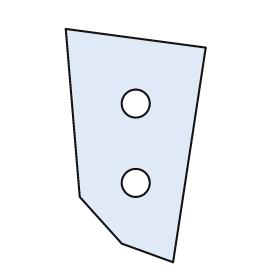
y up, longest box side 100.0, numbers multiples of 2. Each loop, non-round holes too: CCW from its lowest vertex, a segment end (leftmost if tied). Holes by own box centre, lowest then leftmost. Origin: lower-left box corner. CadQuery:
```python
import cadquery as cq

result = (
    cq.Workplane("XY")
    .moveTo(46.0, 0.0)
    .lineTo(60.0, 92.0)
    .lineTo(0.0, 100.0)
    .lineTo(6.0, 28.0)
    .lineTo(24.0, 8.0)
    .close()
    .moveTo(30.0, 34.0)
    .circle(6.0)
    .moveTo(30.0, 68.0)
    .circle(6.0)
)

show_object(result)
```